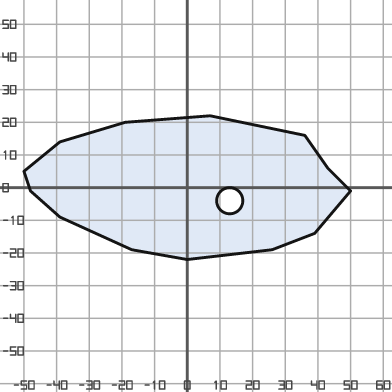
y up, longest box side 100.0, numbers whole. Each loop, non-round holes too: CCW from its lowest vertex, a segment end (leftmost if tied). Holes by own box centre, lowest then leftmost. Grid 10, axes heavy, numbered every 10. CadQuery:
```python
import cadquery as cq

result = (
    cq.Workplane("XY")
    .moveTo(0.0, -22.0)
    .lineTo(26.0, -19.0)
    .lineTo(39.0, -14.0)
    .lineTo(50.0, -1.0)
    .lineTo(43.0, 6.0)
    .lineTo(36.0, 16.0)
    .lineTo(7.0, 22.0)
    .lineTo(-19.0, 20.0)
    .lineTo(-39.0, 14.0)
    .lineTo(-50.0, 5.0)
    .lineTo(-48.0, -1.0)
    .lineTo(-39.0, -9.0)
    .lineTo(-17.0, -19.0)
    .close()
    .moveTo(13.0, -4.0)
    .circle(4.0)
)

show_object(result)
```